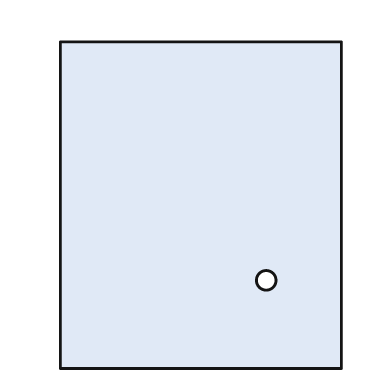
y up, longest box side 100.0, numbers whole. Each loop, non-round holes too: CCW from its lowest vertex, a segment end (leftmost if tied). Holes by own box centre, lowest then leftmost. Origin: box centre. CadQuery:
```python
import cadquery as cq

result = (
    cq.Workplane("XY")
    .moveTo(-43.0, -50.0)
    .lineTo(43.0, -50.0)
    .lineTo(43.0, 50.0)
    .lineTo(-43.0, 50.0)
    .close()
    .moveTo(20.0, -23.0)
    .circle(3.0)
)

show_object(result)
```